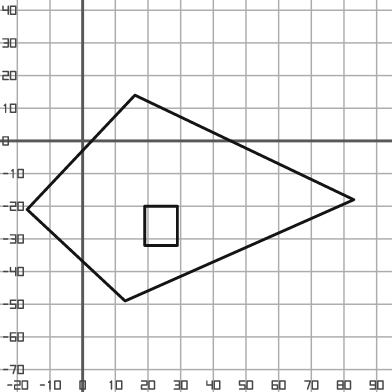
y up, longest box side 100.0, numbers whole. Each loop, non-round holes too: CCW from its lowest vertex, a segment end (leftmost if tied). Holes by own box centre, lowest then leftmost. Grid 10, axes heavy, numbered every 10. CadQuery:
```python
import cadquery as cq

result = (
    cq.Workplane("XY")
    .moveTo(13.0, -49.0)
    .lineTo(83.0, -18.0)
    .lineTo(16.0, 14.0)
    .lineTo(-17.0, -21.0)
    .close()
    .moveTo(19.0, -32.0)
    .lineTo(29.0, -32.0)
    .lineTo(29.0, -20.0)
    .lineTo(19.0, -20.0)
    .close()
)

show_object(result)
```